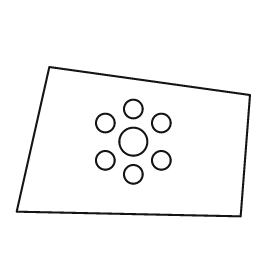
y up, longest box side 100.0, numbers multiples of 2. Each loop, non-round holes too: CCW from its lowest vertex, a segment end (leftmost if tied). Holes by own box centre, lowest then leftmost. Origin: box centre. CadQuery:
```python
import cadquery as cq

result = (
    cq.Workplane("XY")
    .moveTo(46.0, -32.0)
    .lineTo(50.0, 20.0)
    .lineTo(-36.0, 32.0)
    .lineTo(-50.0, -30.0)
    .close()
    .moveTo(0.0, -14.0)
    .circle(4.0)
    .moveTo(-12.0, -8.0)
    .circle(4.0)
    .moveTo(12.0, -8.0)
    .circle(4.0)
    .moveTo(0.0, 0.0)
    .circle(6.0)
    .moveTo(-12.0, 8.0)
    .circle(4.0)
    .moveTo(12.0, 8.0)
    .circle(4.0)
    .moveTo(0.0, 14.0)
    .circle(4.0)
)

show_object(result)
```